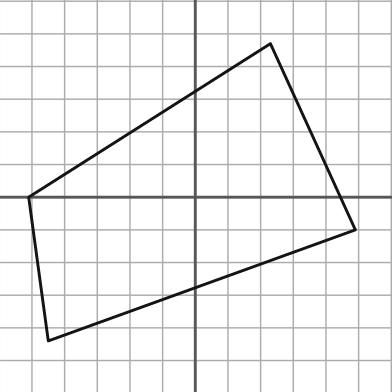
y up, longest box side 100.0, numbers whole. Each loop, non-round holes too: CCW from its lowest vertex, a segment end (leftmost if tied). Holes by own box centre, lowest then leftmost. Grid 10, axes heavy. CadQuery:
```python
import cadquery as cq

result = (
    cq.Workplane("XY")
    .moveTo(-45.0, -44.0)
    .lineTo(49.0, -10.0)
    .lineTo(23.0, 47.0)
    .lineTo(-51.0, 0.0)
    .close()
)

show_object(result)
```